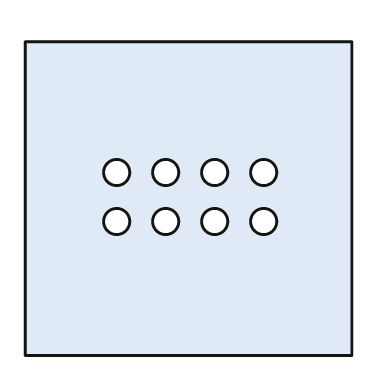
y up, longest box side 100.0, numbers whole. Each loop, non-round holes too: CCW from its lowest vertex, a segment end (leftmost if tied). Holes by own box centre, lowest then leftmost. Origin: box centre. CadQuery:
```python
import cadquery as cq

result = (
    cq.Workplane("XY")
    .moveTo(-50.0, -48.0)
    .lineTo(50.0, -48.0)
    .lineTo(50.0, 48.0)
    .lineTo(-50.0, 48.0)
    .close()
    .moveTo(-22.0, -7.0)
    .circle(4.0)
    .moveTo(-7.0, -7.0)
    .circle(4.0)
    .moveTo(8.0, -7.0)
    .circle(4.0)
    .moveTo(23.0, -7.0)
    .circle(4.0)
    .moveTo(-22.0, 8.0)
    .circle(4.0)
    .moveTo(-7.0, 8.0)
    .circle(4.0)
    .moveTo(8.0, 8.0)
    .circle(4.0)
    .moveTo(23.0, 8.0)
    .circle(4.0)
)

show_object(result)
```